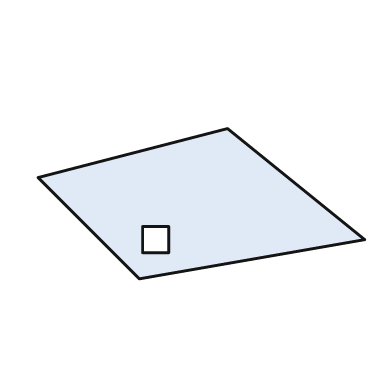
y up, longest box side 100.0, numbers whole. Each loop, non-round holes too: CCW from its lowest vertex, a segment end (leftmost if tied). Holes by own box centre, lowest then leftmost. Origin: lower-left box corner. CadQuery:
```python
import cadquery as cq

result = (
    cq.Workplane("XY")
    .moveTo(31.0, 0.0)
    .lineTo(100.0, 12.0)
    .lineTo(58.0, 46.0)
    .lineTo(0.0, 31.0)
    .close()
    .moveTo(32.0, 8.0)
    .lineTo(40.0, 8.0)
    .lineTo(40.0, 16.0)
    .lineTo(32.0, 16.0)
    .close()
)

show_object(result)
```